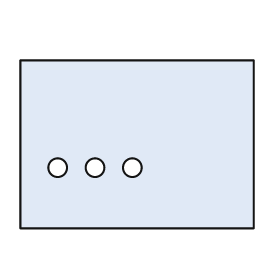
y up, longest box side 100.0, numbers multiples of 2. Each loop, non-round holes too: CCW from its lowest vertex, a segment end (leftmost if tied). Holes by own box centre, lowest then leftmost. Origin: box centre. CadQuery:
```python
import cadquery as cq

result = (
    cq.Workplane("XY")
    .moveTo(-50.0, -36.0)
    .lineTo(50.0, -36.0)
    .lineTo(50.0, 36.0)
    .lineTo(-50.0, 36.0)
    .close()
    .moveTo(-34.0, -10.0)
    .circle(4.0)
    .moveTo(-18.0, -10.0)
    .circle(4.0)
    .moveTo(-2.0, -10.0)
    .circle(4.0)
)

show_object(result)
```